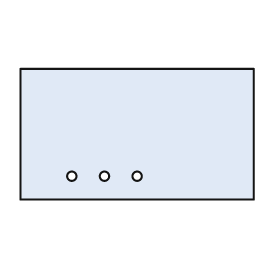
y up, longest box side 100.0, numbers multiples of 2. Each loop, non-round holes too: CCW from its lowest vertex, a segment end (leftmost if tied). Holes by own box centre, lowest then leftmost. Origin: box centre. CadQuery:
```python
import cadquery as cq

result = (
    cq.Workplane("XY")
    .moveTo(-50.0, -28.0)
    .lineTo(50.0, -28.0)
    .lineTo(50.0, 28.0)
    .lineTo(-50.0, 28.0)
    .close()
    .moveTo(-28.0, -18.0)
    .circle(2.0)
    .moveTo(-14.0, -18.0)
    .circle(2.0)
    .moveTo(0.0, -18.0)
    .circle(2.0)
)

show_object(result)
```